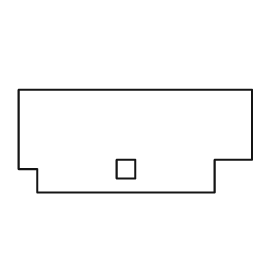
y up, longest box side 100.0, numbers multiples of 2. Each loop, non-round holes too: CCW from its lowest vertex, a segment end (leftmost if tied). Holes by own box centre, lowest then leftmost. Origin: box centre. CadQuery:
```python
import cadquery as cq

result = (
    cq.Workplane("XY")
    .moveTo(-42.0, -22.0)
    .lineTo(34.0, -22.0)
    .lineTo(34.0, -8.0)
    .lineTo(50.0, -8.0)
    .lineTo(50.0, 22.0)
    .lineTo(-50.0, 22.0)
    .lineTo(-50.0, -12.0)
    .lineTo(-42.0, -12.0)
    .close()
    .moveTo(-8.0, -16.0)
    .lineTo(0.0, -16.0)
    .lineTo(0.0, -8.0)
    .lineTo(-8.0, -8.0)
    .close()
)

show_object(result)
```